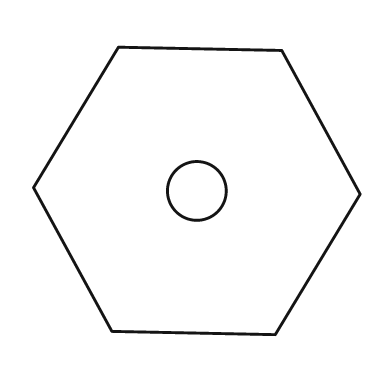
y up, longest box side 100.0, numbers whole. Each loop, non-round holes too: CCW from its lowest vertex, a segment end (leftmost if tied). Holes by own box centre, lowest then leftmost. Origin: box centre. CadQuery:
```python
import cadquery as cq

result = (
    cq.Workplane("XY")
    .moveTo(24.0, -44.0)
    .lineTo(50.0, -1.0)
    .lineTo(26.0, 43.0)
    .lineTo(-24.0, 44.0)
    .lineTo(-50.0, 1.0)
    .lineTo(-26.0, -43.0)
    .close()
    .moveTo(0.0, 0.0)
    .circle(9.0)
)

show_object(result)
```